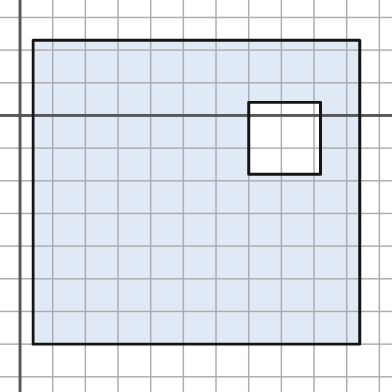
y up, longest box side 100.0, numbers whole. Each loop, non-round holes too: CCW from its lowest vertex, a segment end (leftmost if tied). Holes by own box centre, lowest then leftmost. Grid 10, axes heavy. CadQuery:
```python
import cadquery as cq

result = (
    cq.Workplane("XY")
    .moveTo(4.0, -70.0)
    .lineTo(104.0, -70.0)
    .lineTo(104.0, 23.0)
    .lineTo(4.0, 23.0)
    .close()
    .moveTo(70.0, -18.0)
    .lineTo(92.0, -18.0)
    .lineTo(92.0, 4.0)
    .lineTo(70.0, 4.0)
    .close()
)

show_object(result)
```